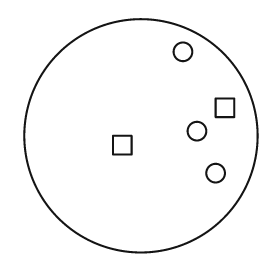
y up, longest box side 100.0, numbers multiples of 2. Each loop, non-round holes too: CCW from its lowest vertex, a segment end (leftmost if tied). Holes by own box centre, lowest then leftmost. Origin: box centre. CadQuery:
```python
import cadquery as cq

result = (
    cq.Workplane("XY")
    .moveTo(0.0, 0.0)
    .circle(50.0)
    .moveTo(32.0, -16.0)
    .circle(4.0)
    .moveTo(-12.0, -8.0)
    .lineTo(-4.0, -8.0)
    .lineTo(-4.0, 0.0)
    .lineTo(-12.0, 0.0)
    .close()
    .moveTo(24.0, 2.0)
    .circle(4.0)
    .moveTo(32.0, 8.0)
    .lineTo(40.0, 8.0)
    .lineTo(40.0, 16.0)
    .lineTo(32.0, 16.0)
    .close()
    .moveTo(18.0, 36.0)
    .circle(4.0)
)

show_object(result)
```